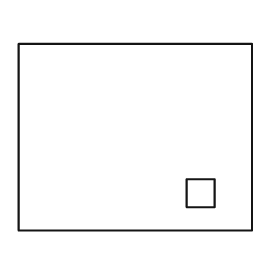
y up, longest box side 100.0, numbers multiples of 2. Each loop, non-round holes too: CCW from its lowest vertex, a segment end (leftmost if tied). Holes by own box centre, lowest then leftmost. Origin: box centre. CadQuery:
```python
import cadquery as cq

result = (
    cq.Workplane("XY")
    .moveTo(-50.0, -40.0)
    .lineTo(50.0, -40.0)
    .lineTo(50.0, 40.0)
    .lineTo(-50.0, 40.0)
    .close()
    .moveTo(22.0, -30.0)
    .lineTo(34.0, -30.0)
    .lineTo(34.0, -18.0)
    .lineTo(22.0, -18.0)
    .close()
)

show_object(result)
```